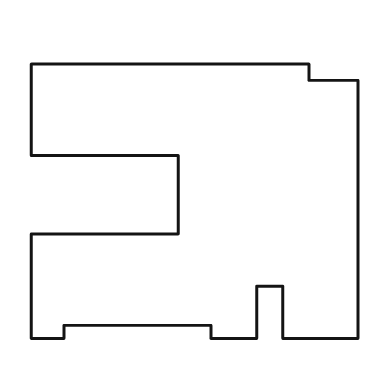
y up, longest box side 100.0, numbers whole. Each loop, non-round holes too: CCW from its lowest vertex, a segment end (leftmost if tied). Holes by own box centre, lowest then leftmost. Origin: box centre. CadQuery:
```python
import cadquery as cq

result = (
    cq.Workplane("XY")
    .moveTo(-50.0, -42.0)
    .lineTo(-40.0, -42.0)
    .lineTo(-40.0, -38.0)
    .lineTo(5.0, -38.0)
    .lineTo(5.0, -42.0)
    .lineTo(19.0, -42.0)
    .lineTo(19.0, -26.0)
    .lineTo(27.0, -26.0)
    .lineTo(27.0, -42.0)
    .lineTo(50.0, -42.0)
    .lineTo(50.0, 37.0)
    .lineTo(35.0, 37.0)
    .lineTo(35.0, 42.0)
    .lineTo(-50.0, 42.0)
    .lineTo(-50.0, 14.0)
    .lineTo(-5.0, 14.0)
    .lineTo(-5.0, -10.0)
    .lineTo(-50.0, -10.0)
    .close()
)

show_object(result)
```